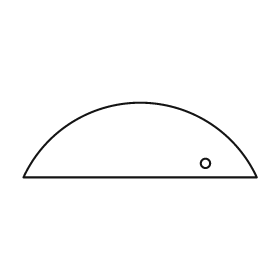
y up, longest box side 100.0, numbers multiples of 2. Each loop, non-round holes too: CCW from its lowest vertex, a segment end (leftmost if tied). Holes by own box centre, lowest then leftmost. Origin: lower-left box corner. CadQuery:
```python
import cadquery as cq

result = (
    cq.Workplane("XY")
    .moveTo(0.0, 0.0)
    .lineTo(100.0, 0.0)
    .threePointArc((50.0, 32.0), (0.0, 0.0))
    .close()
    .moveTo(78.0, 6.0)
    .circle(2.0)
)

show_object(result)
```